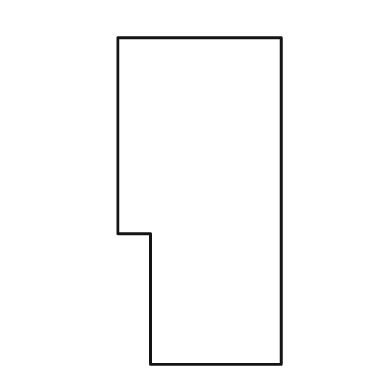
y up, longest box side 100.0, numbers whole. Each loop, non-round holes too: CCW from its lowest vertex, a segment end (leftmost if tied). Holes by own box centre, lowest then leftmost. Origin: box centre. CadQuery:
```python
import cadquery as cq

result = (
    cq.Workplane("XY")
    .moveTo(-15.0, -50.0)
    .lineTo(25.0, -50.0)
    .lineTo(25.0, 50.0)
    .lineTo(-25.0, 50.0)
    .lineTo(-25.0, -10.0)
    .lineTo(-15.0, -10.0)
    .close()
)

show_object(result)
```